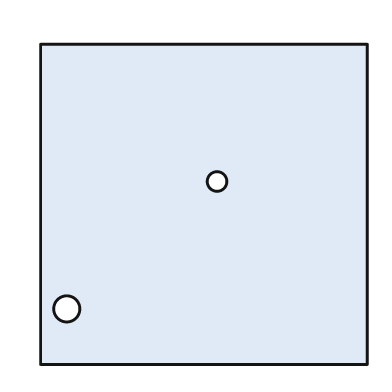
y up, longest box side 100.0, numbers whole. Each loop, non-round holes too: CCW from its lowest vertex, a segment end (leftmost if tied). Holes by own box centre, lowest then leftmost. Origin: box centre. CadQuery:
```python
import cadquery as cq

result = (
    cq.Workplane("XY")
    .moveTo(-50.0, -49.0)
    .lineTo(50.0, -49.0)
    .lineTo(50.0, 49.0)
    .lineTo(-50.0, 49.0)
    .close()
    .moveTo(-42.0, -32.0)
    .circle(4.0)
    .moveTo(4.0, 7.0)
    .circle(3.0)
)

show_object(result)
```